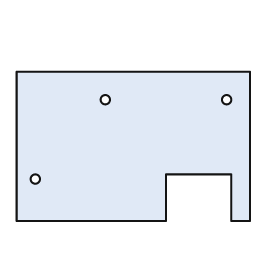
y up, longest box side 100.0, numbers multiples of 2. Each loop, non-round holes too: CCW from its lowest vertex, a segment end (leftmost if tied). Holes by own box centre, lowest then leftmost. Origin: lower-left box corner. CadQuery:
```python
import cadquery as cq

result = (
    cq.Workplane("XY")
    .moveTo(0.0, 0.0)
    .lineTo(64.0, 0.0)
    .lineTo(64.0, 20.0)
    .lineTo(92.0, 20.0)
    .lineTo(92.0, 0.0)
    .lineTo(100.0, 0.0)
    .lineTo(100.0, 64.0)
    .lineTo(0.0, 64.0)
    .close()
    .moveTo(8.0, 18.0)
    .circle(2.0)
    .moveTo(38.0, 52.0)
    .circle(2.0)
    .moveTo(90.0, 52.0)
    .circle(2.0)
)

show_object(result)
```